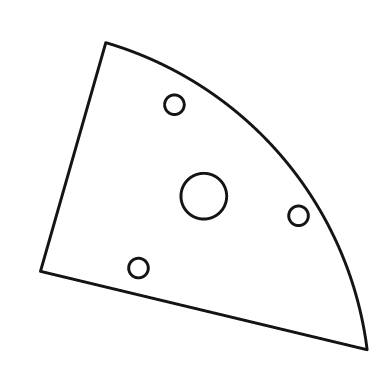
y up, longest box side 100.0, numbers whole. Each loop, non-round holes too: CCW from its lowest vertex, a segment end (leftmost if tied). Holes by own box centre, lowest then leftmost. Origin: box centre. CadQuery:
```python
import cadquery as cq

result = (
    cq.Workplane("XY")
    .moveTo(50.0, -47.0)
    .threePointArc((24.0, 12.0), (-30.0, 47.0))
    .lineTo(-50.0, -23.0)
    .close()
    .moveTo(-20.0, -22.0)
    .circle(3.0)
    .moveTo(29.0, -6.0)
    .circle(3.0)
    .moveTo(0.0, 0.0)
    .circle(7.0)
    .moveTo(-9.0, 28.0)
    .circle(3.0)
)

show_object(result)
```